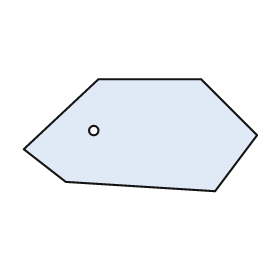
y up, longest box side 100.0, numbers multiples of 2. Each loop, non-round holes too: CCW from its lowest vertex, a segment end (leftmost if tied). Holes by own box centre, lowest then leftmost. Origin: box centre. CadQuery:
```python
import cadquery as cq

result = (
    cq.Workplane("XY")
    .moveTo(32.0, -24.0)
    .lineTo(50.0, 0.0)
    .lineTo(26.0, 24.0)
    .lineTo(-18.0, 24.0)
    .lineTo(-50.0, -6.0)
    .lineTo(-32.0, -20.0)
    .close()
    .moveTo(-20.0, 2.0)
    .circle(2.0)
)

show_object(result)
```